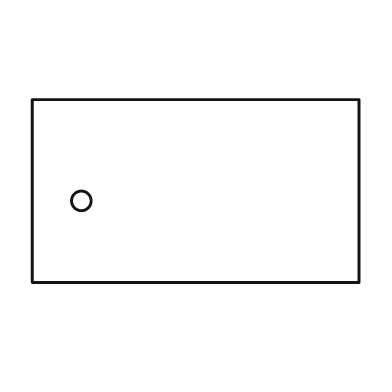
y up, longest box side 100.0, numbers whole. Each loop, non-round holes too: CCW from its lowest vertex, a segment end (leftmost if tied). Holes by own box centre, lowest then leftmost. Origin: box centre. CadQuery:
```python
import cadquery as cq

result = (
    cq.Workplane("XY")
    .moveTo(-50.0, -28.0)
    .lineTo(50.0, -28.0)
    .lineTo(50.0, 28.0)
    .lineTo(-50.0, 28.0)
    .close()
    .moveTo(-35.0, -3.0)
    .circle(3.0)
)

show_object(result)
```